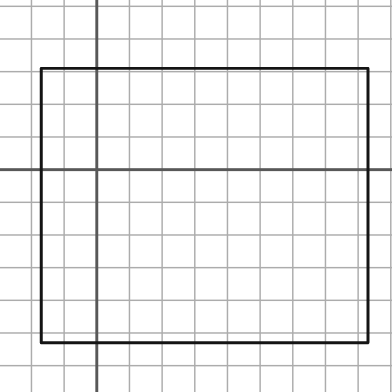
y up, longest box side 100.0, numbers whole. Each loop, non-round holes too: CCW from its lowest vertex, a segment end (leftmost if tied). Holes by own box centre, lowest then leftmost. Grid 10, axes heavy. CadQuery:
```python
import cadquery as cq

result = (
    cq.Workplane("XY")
    .moveTo(-17.0, -53.0)
    .lineTo(83.0, -53.0)
    .lineTo(83.0, 31.0)
    .lineTo(-17.0, 31.0)
    .close()
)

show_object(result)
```